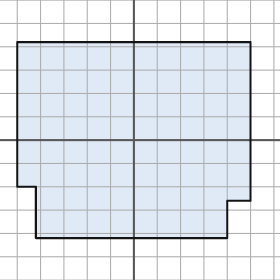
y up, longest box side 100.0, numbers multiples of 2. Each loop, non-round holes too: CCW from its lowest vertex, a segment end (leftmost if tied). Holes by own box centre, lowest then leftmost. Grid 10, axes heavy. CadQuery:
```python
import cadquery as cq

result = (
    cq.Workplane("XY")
    .moveTo(-42.0, -42.0)
    .lineTo(40.0, -42.0)
    .lineTo(40.0, -26.0)
    .lineTo(50.0, -26.0)
    .lineTo(50.0, 42.0)
    .lineTo(-50.0, 42.0)
    .lineTo(-50.0, -20.0)
    .lineTo(-42.0, -20.0)
    .close()
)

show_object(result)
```